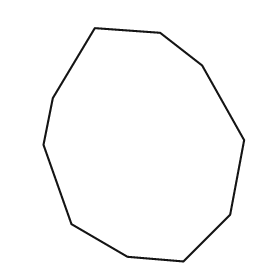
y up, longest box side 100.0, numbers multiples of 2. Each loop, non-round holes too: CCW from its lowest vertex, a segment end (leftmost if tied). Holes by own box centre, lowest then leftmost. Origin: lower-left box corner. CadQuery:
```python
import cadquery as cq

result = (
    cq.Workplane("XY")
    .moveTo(60.0, 0.0)
    .lineTo(80.0, 20.0)
    .lineTo(86.0, 52.0)
    .lineTo(68.0, 84.0)
    .lineTo(50.0, 98.0)
    .lineTo(22.0, 100.0)
    .lineTo(4.0, 70.0)
    .lineTo(0.0, 50.0)
    .lineTo(12.0, 16.0)
    .lineTo(36.0, 2.0)
    .close()
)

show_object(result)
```